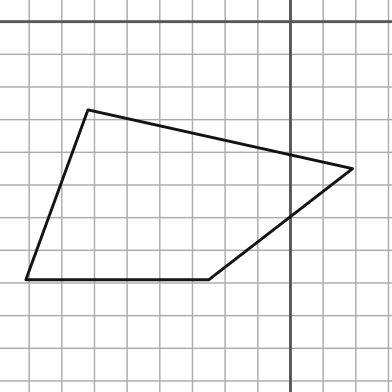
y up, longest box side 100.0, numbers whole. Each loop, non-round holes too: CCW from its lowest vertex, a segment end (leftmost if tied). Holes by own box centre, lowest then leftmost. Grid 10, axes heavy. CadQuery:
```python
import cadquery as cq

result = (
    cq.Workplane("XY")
    .moveTo(-81.0, -79.0)
    .lineTo(-25.0, -79.0)
    .lineTo(19.0, -45.0)
    .lineTo(-62.0, -27.0)
    .close()
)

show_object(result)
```